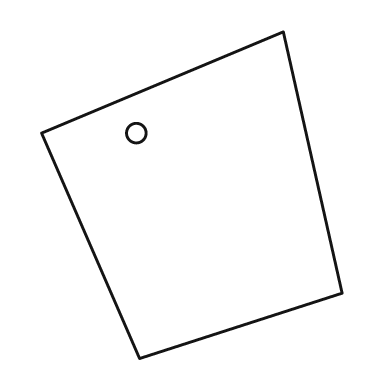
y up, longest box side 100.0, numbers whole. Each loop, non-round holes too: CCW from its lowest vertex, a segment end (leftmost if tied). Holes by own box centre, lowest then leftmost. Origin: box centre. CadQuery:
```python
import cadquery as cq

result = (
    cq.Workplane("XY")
    .moveTo(-16.0, -50.0)
    .lineTo(46.0, -30.0)
    .lineTo(28.0, 50.0)
    .lineTo(-46.0, 19.0)
    .close()
    .moveTo(-17.0, 19.0)
    .circle(3.0)
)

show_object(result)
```